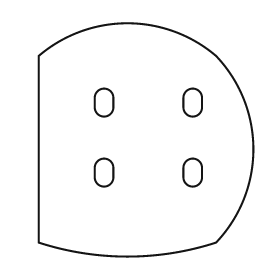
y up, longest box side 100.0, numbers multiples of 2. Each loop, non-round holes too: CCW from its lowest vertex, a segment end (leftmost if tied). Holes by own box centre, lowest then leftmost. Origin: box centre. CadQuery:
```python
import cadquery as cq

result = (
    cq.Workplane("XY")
    .moveTo(-46.0, -44.0)
    .threePointArc((-8.0, -50.0), (30.0, -44.0))
    .threePointArc((46.0, -4.0), (30.0, 36.0))
    .threePointArc((-8.0, 50.0), (-46.0, 36.0))
    .close()
    .moveTo(-22.0, -16.0)
    .threePointArc((-18.0, -20.0), (-14.0, -16.0))
    .lineTo(-14.0, -12.0)
    .threePointArc((-18.0, -8.0), (-22.0, -12.0))
    .close()
    .moveTo(16.0, -16.0)
    .threePointArc((20.0, -20.0), (24.0, -16.0))
    .lineTo(24.0, -12.0)
    .threePointArc((20.0, -8.0), (16.0, -12.0))
    .close()
    .moveTo(-22.0, 14.0)
    .threePointArc((-18.0, 10.0), (-14.0, 14.0))
    .lineTo(-14.0, 18.0)
    .threePointArc((-18.0, 22.0), (-22.0, 18.0))
    .close()
    .moveTo(16.0, 14.0)
    .threePointArc((20.0, 10.0), (24.0, 14.0))
    .lineTo(24.0, 18.0)
    .threePointArc((20.0, 22.0), (16.0, 18.0))
    .close()
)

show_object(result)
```